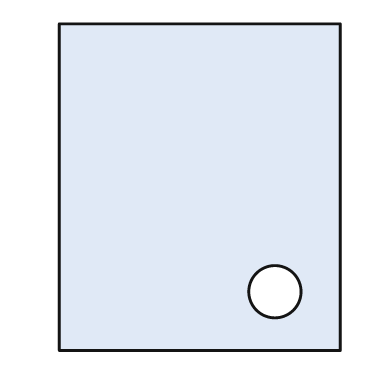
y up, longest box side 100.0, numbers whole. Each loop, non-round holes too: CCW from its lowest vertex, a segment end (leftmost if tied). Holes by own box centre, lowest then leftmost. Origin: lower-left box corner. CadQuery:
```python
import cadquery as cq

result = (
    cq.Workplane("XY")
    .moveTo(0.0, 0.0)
    .lineTo(86.0, 0.0)
    .lineTo(86.0, 100.0)
    .lineTo(0.0, 100.0)
    .close()
    .moveTo(66.0, 18.0)
    .circle(8.0)
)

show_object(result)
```